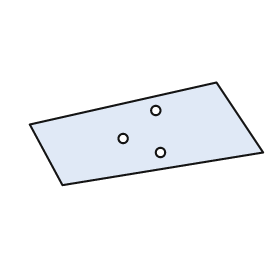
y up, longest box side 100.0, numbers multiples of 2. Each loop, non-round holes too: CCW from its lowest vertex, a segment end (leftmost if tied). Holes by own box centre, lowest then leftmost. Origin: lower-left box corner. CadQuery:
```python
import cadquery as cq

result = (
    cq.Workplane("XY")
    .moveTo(14.0, 0.0)
    .lineTo(100.0, 14.0)
    .lineTo(80.0, 44.0)
    .lineTo(0.0, 26.0)
    .close()
    .moveTo(56.0, 14.0)
    .circle(2.0)
    .moveTo(40.0, 20.0)
    .circle(2.0)
    .moveTo(54.0, 32.0)
    .circle(2.0)
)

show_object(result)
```